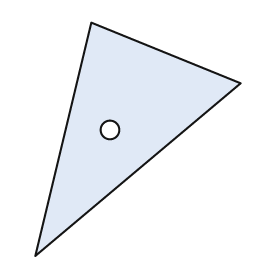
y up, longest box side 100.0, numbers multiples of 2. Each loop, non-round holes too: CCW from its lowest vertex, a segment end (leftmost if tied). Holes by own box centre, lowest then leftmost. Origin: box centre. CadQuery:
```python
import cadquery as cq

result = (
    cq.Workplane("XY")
    .moveTo(-44.0, -50.0)
    .lineTo(44.0, 24.0)
    .lineTo(-20.0, 50.0)
    .close()
    .moveTo(-12.0, 4.0)
    .circle(4.0)
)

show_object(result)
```